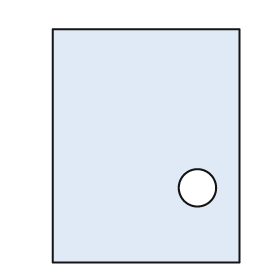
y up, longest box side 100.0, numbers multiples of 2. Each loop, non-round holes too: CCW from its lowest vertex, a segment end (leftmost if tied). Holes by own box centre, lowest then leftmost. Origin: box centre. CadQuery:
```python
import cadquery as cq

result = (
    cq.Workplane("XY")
    .moveTo(-40.0, -50.0)
    .lineTo(40.0, -50.0)
    .lineTo(40.0, 50.0)
    .lineTo(-40.0, 50.0)
    .close()
    .moveTo(22.0, -18.0)
    .circle(8.0)
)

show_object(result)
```